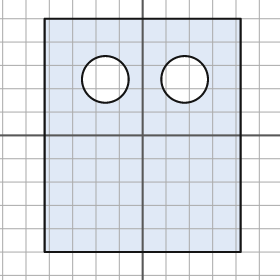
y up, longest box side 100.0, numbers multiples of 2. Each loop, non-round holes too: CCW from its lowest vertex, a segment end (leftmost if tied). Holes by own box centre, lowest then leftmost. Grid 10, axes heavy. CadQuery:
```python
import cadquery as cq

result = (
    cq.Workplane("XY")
    .moveTo(-42.0, -50.0)
    .lineTo(42.0, -50.0)
    .lineTo(42.0, 50.0)
    .lineTo(-42.0, 50.0)
    .close()
    .moveTo(-16.0, 24.0)
    .circle(10.0)
    .moveTo(18.0, 24.0)
    .circle(10.0)
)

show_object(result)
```